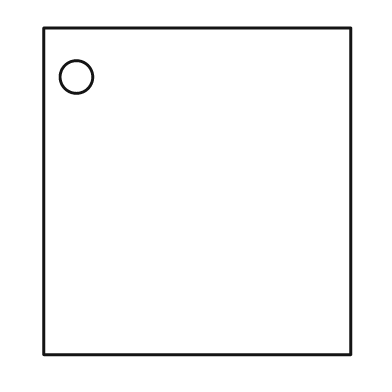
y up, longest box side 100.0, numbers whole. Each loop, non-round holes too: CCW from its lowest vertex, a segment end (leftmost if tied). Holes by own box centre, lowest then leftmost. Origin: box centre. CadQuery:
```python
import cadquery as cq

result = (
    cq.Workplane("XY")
    .moveTo(-47.0, -50.0)
    .lineTo(47.0, -50.0)
    .lineTo(47.0, 50.0)
    .lineTo(-47.0, 50.0)
    .close()
    .moveTo(-37.0, 35.0)
    .circle(5.0)
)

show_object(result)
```